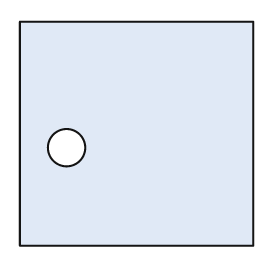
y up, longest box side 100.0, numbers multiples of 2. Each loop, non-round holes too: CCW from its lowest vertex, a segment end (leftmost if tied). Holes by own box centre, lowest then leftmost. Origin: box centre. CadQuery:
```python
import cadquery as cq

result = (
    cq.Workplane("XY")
    .moveTo(-50.0, -48.0)
    .lineTo(50.0, -48.0)
    .lineTo(50.0, 48.0)
    .lineTo(-50.0, 48.0)
    .close()
    .moveTo(-30.0, -6.0)
    .circle(8.0)
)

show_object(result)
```